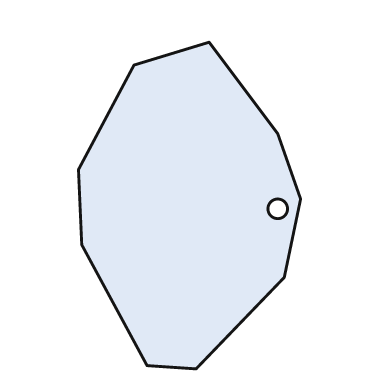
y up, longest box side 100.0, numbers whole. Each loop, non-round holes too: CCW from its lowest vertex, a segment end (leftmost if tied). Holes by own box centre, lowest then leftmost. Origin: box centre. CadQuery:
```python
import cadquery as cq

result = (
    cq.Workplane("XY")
    .moveTo(2.0, -50.0)
    .lineTo(29.0, -22.0)
    .lineTo(34.0, 2.0)
    .lineTo(27.0, 22.0)
    .lineTo(6.0, 50.0)
    .lineTo(-17.0, 43.0)
    .lineTo(-34.0, 11.0)
    .lineTo(-33.0, -12.0)
    .lineTo(-13.0, -49.0)
    .close()
    .moveTo(27.0, -1.0)
    .circle(3.0)
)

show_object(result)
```